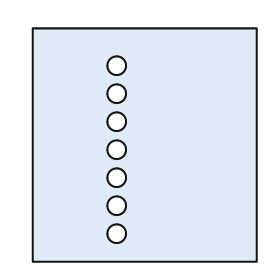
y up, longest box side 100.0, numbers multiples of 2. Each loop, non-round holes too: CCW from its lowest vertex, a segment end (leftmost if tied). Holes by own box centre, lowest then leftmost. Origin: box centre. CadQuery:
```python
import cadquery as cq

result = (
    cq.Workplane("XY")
    .moveTo(-48.0, -50.0)
    .lineTo(48.0, -50.0)
    .lineTo(48.0, 50.0)
    .lineTo(-48.0, 50.0)
    .close()
    .moveTo(-12.0, -38.0)
    .circle(4.0)
    .moveTo(-12.0, -26.0)
    .circle(4.0)
    .moveTo(-12.0, -14.0)
    .circle(4.0)
    .moveTo(-12.0, -2.0)
    .circle(4.0)
    .moveTo(-12.0, 10.0)
    .circle(4.0)
    .moveTo(-12.0, 22.0)
    .circle(4.0)
    .moveTo(-12.0, 34.0)
    .circle(4.0)
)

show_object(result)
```